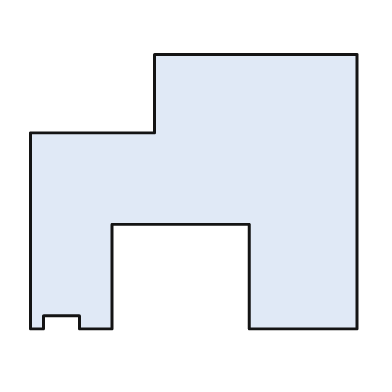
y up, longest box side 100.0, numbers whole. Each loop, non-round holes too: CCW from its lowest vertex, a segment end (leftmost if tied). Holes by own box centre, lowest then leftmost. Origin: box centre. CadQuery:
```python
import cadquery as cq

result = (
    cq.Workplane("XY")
    .moveTo(-50.0, -42.0)
    .lineTo(-46.0, -42.0)
    .lineTo(-46.0, -38.0)
    .lineTo(-35.0, -38.0)
    .lineTo(-35.0, -42.0)
    .lineTo(-25.0, -42.0)
    .lineTo(-25.0, -10.0)
    .lineTo(17.0, -10.0)
    .lineTo(17.0, -42.0)
    .lineTo(50.0, -42.0)
    .lineTo(50.0, 42.0)
    .lineTo(-12.0, 42.0)
    .lineTo(-12.0, 18.0)
    .lineTo(-50.0, 18.0)
    .close()
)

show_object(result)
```